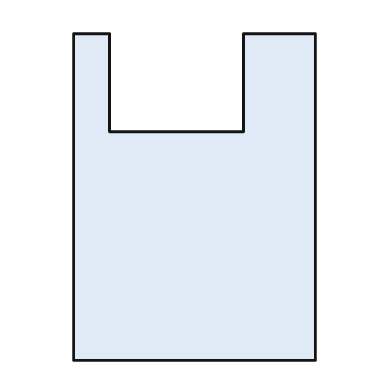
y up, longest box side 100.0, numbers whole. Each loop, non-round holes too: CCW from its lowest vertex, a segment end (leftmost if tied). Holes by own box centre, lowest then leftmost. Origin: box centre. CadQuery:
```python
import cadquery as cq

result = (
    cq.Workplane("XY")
    .moveTo(-37.0, -50.0)
    .lineTo(37.0, -50.0)
    .lineTo(37.0, 50.0)
    .lineTo(15.0, 50.0)
    .lineTo(15.0, 20.0)
    .lineTo(-26.0, 20.0)
    .lineTo(-26.0, 50.0)
    .lineTo(-37.0, 50.0)
    .close()
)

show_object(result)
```